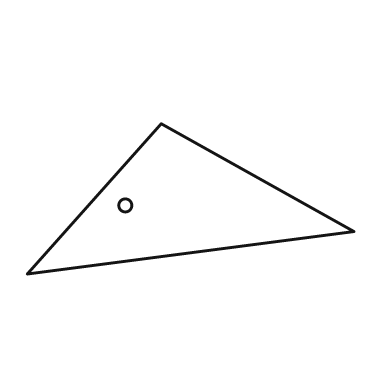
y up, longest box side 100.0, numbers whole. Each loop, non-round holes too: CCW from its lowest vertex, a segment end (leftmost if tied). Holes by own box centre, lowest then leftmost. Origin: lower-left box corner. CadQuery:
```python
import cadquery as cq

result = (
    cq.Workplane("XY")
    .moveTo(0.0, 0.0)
    .lineTo(100.0, 13.0)
    .lineTo(41.0, 46.0)
    .close()
    .moveTo(30.0, 21.0)
    .circle(2.0)
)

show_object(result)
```